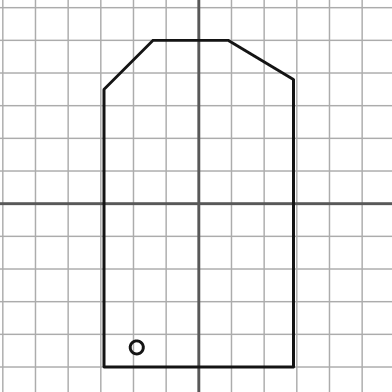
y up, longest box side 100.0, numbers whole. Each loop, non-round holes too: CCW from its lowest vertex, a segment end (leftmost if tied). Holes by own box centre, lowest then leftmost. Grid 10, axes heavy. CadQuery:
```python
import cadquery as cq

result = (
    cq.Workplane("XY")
    .moveTo(-29.0, -50.0)
    .lineTo(29.0, -50.0)
    .lineTo(29.0, 38.0)
    .lineTo(9.0, 50.0)
    .lineTo(-14.0, 50.0)
    .lineTo(-29.0, 35.0)
    .close()
    .moveTo(-19.0, -44.0)
    .circle(2.0)
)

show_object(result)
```